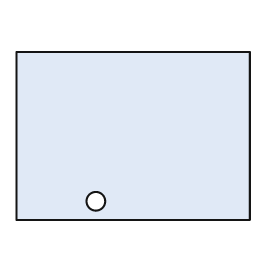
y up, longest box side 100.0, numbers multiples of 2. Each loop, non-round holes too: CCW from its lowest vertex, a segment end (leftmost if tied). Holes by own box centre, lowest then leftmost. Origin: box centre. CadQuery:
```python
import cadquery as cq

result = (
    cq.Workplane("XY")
    .moveTo(-50.0, -36.0)
    .lineTo(50.0, -36.0)
    .lineTo(50.0, 36.0)
    .lineTo(-50.0, 36.0)
    .close()
    .moveTo(-16.0, -28.0)
    .circle(4.0)
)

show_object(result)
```